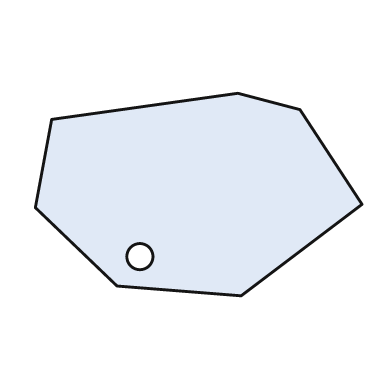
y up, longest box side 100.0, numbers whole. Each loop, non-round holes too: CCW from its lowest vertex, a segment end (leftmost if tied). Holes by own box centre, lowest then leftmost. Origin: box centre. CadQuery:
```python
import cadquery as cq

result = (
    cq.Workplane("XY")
    .moveTo(13.0, -31.0)
    .lineTo(50.0, -3.0)
    .lineTo(31.0, 26.0)
    .lineTo(12.0, 31.0)
    .lineTo(-45.0, 23.0)
    .lineTo(-50.0, -4.0)
    .lineTo(-25.0, -28.0)
    .close()
    .moveTo(-18.0, -19.0)
    .circle(4.0)
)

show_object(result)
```